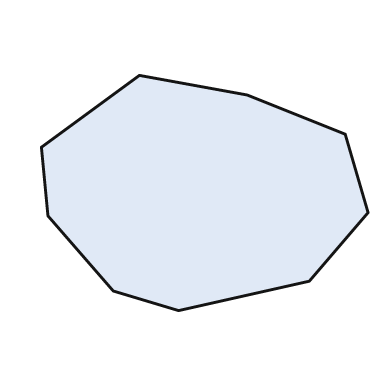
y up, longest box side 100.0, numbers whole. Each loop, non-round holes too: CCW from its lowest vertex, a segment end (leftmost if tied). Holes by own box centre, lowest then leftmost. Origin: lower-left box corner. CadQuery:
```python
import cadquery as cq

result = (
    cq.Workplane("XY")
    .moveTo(42.0, 0.0)
    .lineTo(82.0, 9.0)
    .lineTo(100.0, 30.0)
    .lineTo(93.0, 54.0)
    .lineTo(63.0, 66.0)
    .lineTo(30.0, 72.0)
    .lineTo(0.0, 50.0)
    .lineTo(2.0, 29.0)
    .lineTo(22.0, 6.0)
    .close()
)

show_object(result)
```